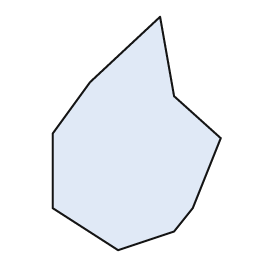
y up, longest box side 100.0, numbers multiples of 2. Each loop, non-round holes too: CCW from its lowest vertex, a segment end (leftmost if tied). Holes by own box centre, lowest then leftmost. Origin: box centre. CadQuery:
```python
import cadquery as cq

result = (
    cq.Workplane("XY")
    .moveTo(-8.0, -50.0)
    .lineTo(16.0, -42.0)
    .lineTo(24.0, -32.0)
    .lineTo(36.0, -2.0)
    .lineTo(16.0, 16.0)
    .lineTo(10.0, 50.0)
    .lineTo(-20.0, 22.0)
    .lineTo(-36.0, 0.0)
    .lineTo(-36.0, -32.0)
    .close()
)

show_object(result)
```